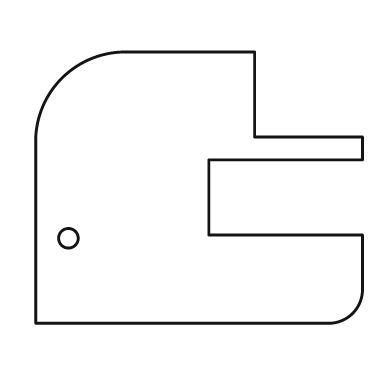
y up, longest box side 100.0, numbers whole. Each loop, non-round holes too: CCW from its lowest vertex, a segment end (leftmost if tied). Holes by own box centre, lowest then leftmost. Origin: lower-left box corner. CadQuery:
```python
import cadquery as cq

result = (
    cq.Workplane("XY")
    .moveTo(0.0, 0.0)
    .lineTo(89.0, 0.0)
    .threePointArc((97.0, 3.0), (100.0, 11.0))
    .lineTo(100.0, 27.0)
    .lineTo(53.0, 27.0)
    .lineTo(53.0, 50.0)
    .lineTo(100.0, 50.0)
    .lineTo(100.0, 57.0)
    .lineTo(67.0, 57.0)
    .lineTo(67.0, 83.0)
    .lineTo(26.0, 83.0)
    .threePointArc((8.0, 75.0), (0.0, 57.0))
    .close()
    .moveTo(10.0, 26.0)
    .circle(3.0)
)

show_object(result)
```